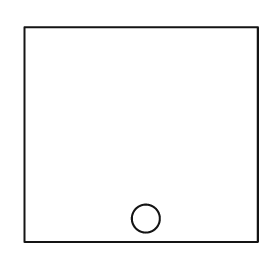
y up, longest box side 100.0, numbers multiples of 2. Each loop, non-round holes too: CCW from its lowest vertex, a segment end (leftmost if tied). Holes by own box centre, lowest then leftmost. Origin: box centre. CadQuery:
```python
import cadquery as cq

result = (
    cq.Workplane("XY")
    .moveTo(-50.0, -46.0)
    .lineTo(50.0, -46.0)
    .lineTo(50.0, 46.0)
    .lineTo(-50.0, 46.0)
    .close()
    .moveTo(2.0, -36.0)
    .circle(6.0)
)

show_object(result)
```